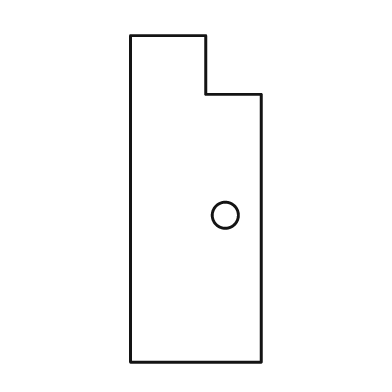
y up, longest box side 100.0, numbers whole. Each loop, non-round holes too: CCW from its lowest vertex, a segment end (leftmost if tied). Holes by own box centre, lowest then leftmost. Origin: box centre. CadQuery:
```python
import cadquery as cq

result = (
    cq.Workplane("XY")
    .moveTo(-20.0, -50.0)
    .lineTo(20.0, -50.0)
    .lineTo(20.0, 32.0)
    .lineTo(3.0, 32.0)
    .lineTo(3.0, 50.0)
    .lineTo(-20.0, 50.0)
    .close()
    .moveTo(9.0, -5.0)
    .circle(4.0)
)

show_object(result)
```